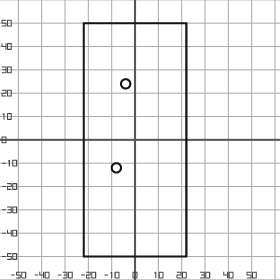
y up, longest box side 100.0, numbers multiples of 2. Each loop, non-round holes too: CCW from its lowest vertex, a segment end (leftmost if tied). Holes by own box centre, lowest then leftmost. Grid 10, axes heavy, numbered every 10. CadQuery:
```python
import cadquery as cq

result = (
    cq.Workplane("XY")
    .moveTo(-22.0, -50.0)
    .lineTo(22.0, -50.0)
    .lineTo(22.0, 50.0)
    .lineTo(-22.0, 50.0)
    .close()
    .moveTo(-8.0, -12.0)
    .circle(2.0)
    .moveTo(-4.0, 24.0)
    .circle(2.0)
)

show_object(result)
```